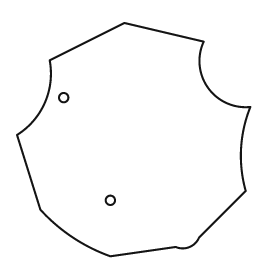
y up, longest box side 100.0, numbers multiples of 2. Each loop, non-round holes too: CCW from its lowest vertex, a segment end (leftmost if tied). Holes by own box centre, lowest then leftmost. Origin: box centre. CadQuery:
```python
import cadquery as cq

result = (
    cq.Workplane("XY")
    .moveTo(-10.0, -50.0)
    .lineTo(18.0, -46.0)
    .threePointArc((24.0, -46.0), (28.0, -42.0))
    .lineTo(48.0, -22.0)
    .threePointArc((46.0, -4.0), (50.0, 14.0))
    .threePointArc((32.0, 22.0), (30.0, 42.0))
    .lineTo(-4.0, 50.0)
    .lineTo(-36.0, 34.0)
    .threePointArc((-38.0, 16.0), (-50.0, 2.0))
    .lineTo(-40.0, -30.0)
    .threePointArc((-26.0, -42.0), (-10.0, -50.0))
    .close()
    .moveTo(-10.0, -26.0)
    .circle(2.0)
    .moveTo(-30.0, 18.0)
    .circle(2.0)
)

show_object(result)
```